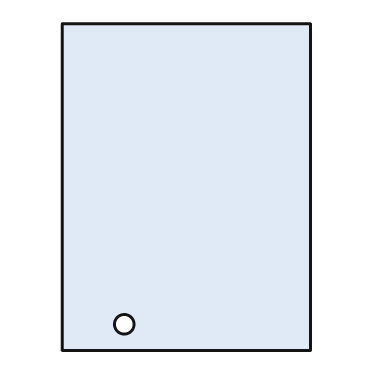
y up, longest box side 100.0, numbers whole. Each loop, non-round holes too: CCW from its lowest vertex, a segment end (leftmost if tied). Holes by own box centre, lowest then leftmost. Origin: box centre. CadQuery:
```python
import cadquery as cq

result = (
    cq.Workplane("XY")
    .moveTo(-38.0, -50.0)
    .lineTo(38.0, -50.0)
    .lineTo(38.0, 50.0)
    .lineTo(-38.0, 50.0)
    .close()
    .moveTo(-19.0, -42.0)
    .circle(3.0)
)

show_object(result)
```